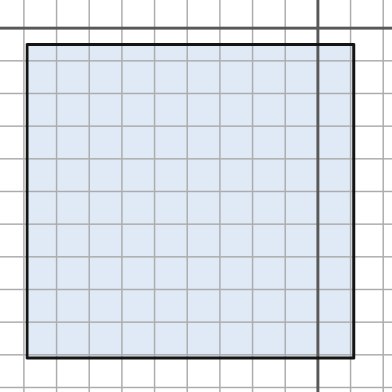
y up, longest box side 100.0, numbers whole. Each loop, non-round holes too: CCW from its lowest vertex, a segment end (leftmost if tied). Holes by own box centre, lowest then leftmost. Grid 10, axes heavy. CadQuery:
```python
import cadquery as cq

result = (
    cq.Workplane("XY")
    .moveTo(-89.0, -101.0)
    .lineTo(11.0, -101.0)
    .lineTo(11.0, -5.0)
    .lineTo(-89.0, -5.0)
    .close()
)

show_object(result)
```